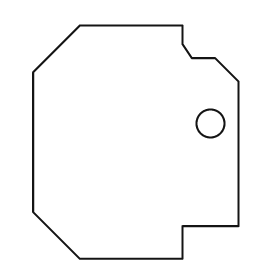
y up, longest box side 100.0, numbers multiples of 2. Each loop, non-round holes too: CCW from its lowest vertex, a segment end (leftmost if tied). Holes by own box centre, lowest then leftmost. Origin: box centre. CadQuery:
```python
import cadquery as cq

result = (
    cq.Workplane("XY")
    .moveTo(-24.0, -50.0)
    .lineTo(20.0, -50.0)
    .lineTo(20.0, -36.0)
    .lineTo(44.0, -36.0)
    .lineTo(44.0, 26.0)
    .lineTo(34.0, 36.0)
    .lineTo(24.0, 36.0)
    .lineTo(20.0, 42.0)
    .lineTo(20.0, 50.0)
    .lineTo(-24.0, 50.0)
    .lineTo(-44.0, 30.0)
    .lineTo(-44.0, -30.0)
    .close()
    .moveTo(32.0, 8.0)
    .circle(6.0)
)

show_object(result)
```